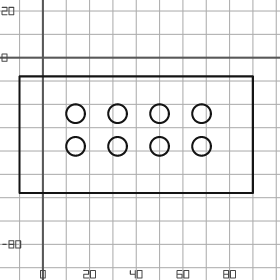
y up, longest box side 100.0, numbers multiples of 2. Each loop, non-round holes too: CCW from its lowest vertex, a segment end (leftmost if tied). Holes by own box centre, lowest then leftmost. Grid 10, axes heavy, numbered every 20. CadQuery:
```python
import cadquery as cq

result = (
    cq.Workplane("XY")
    .moveTo(-10.0, -58.0)
    .lineTo(90.0, -58.0)
    .lineTo(90.0, -8.0)
    .lineTo(-10.0, -8.0)
    .close()
    .moveTo(14.0, -38.0)
    .circle(4.0)
    .moveTo(32.0, -38.0)
    .circle(4.0)
    .moveTo(50.0, -38.0)
    .circle(4.0)
    .moveTo(68.0, -38.0)
    .circle(4.0)
    .moveTo(14.0, -24.0)
    .circle(4.0)
    .moveTo(32.0, -24.0)
    .circle(4.0)
    .moveTo(50.0, -24.0)
    .circle(4.0)
    .moveTo(68.0, -24.0)
    .circle(4.0)
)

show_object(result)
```